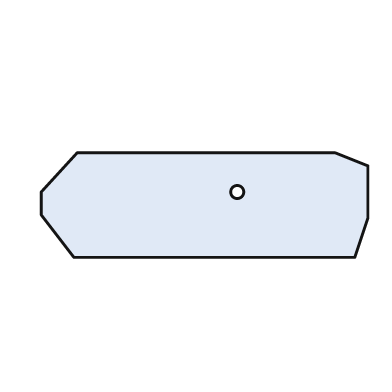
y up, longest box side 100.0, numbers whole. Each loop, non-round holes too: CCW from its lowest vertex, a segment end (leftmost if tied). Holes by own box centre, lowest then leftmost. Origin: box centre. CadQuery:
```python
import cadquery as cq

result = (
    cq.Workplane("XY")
    .moveTo(-40.0, -16.0)
    .lineTo(46.0, -16.0)
    .lineTo(50.0, -4.0)
    .lineTo(50.0, 12.0)
    .lineTo(40.0, 16.0)
    .lineTo(-39.0, 16.0)
    .lineTo(-50.0, 4.0)
    .lineTo(-50.0, -3.0)
    .close()
    .moveTo(10.0, 4.0)
    .circle(2.0)
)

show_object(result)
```